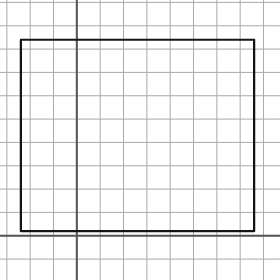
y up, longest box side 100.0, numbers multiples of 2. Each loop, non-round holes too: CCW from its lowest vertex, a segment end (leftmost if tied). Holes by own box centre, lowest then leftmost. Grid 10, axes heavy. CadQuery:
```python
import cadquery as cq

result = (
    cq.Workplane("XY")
    .moveTo(-24.0, 2.0)
    .lineTo(76.0, 2.0)
    .lineTo(76.0, 84.0)
    .lineTo(-24.0, 84.0)
    .close()
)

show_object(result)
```